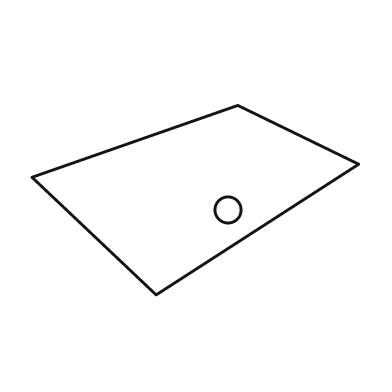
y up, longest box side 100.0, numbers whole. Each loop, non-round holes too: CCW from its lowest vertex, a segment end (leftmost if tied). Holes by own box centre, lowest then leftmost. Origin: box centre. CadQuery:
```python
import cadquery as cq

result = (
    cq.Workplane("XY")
    .moveTo(-12.0, -29.0)
    .lineTo(50.0, 11.0)
    .lineTo(13.0, 29.0)
    .lineTo(-50.0, 7.0)
    .close()
    .moveTo(10.0, -3.0)
    .circle(4.0)
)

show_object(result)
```